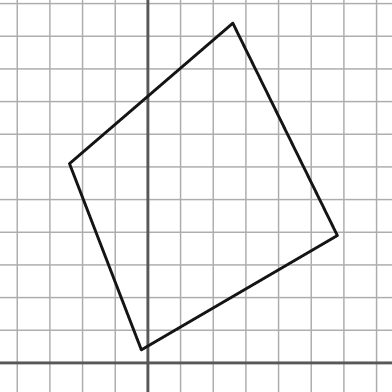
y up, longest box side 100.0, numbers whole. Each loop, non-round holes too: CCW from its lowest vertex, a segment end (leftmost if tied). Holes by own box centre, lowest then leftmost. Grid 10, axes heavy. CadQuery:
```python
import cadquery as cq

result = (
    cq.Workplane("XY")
    .moveTo(-2.0, 4.0)
    .lineTo(58.0, 39.0)
    .lineTo(26.0, 104.0)
    .lineTo(-24.0, 61.0)
    .close()
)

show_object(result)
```